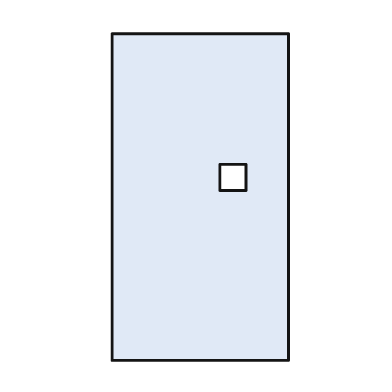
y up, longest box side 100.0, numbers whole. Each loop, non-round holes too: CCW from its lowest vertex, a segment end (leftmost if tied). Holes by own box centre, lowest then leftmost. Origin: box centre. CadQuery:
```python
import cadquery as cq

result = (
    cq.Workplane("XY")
    .moveTo(-27.0, -50.0)
    .lineTo(27.0, -50.0)
    .lineTo(27.0, 50.0)
    .lineTo(-27.0, 50.0)
    .close()
    .moveTo(6.0, 2.0)
    .lineTo(14.0, 2.0)
    .lineTo(14.0, 10.0)
    .lineTo(6.0, 10.0)
    .close()
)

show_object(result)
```